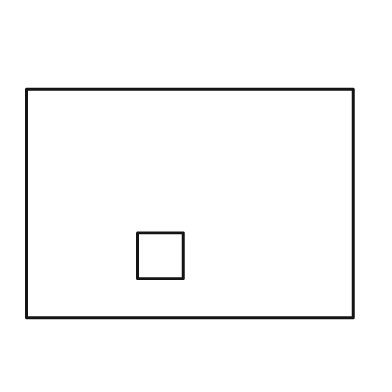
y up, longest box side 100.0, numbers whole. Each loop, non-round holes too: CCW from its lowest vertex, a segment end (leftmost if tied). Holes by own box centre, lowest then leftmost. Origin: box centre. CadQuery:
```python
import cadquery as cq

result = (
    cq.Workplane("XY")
    .moveTo(-50.0, -35.0)
    .lineTo(50.0, -35.0)
    .lineTo(50.0, 35.0)
    .lineTo(-50.0, 35.0)
    .close()
    .moveTo(-16.0, -23.0)
    .lineTo(-2.0, -23.0)
    .lineTo(-2.0, -9.0)
    .lineTo(-16.0, -9.0)
    .close()
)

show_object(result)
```